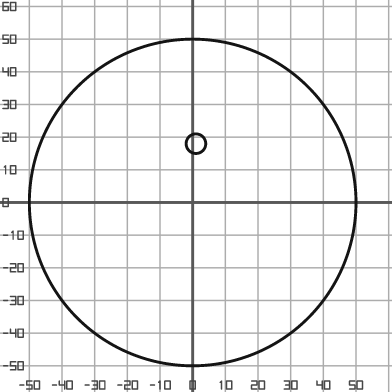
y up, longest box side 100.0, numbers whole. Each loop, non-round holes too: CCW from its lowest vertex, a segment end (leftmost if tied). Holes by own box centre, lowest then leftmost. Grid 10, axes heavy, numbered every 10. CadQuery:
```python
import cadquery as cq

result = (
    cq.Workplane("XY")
    .moveTo(0.0, 0.0)
    .circle(50.0)
    .moveTo(1.0, 18.0)
    .circle(3.0)
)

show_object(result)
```